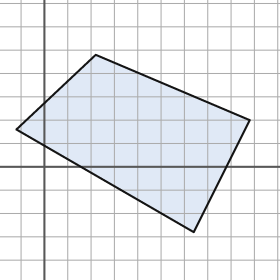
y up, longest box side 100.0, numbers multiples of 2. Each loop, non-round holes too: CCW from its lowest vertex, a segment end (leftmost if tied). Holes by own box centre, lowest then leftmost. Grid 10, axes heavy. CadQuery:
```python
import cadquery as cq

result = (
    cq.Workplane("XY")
    .moveTo(64.0, -28.0)
    .lineTo(88.0, 20.0)
    .lineTo(22.0, 48.0)
    .lineTo(-12.0, 16.0)
    .close()
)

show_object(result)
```